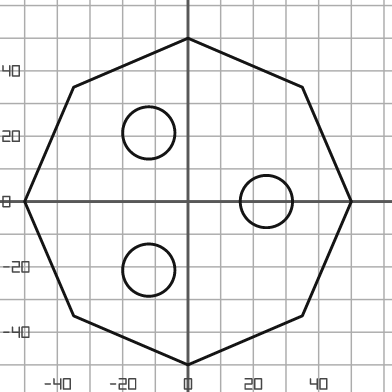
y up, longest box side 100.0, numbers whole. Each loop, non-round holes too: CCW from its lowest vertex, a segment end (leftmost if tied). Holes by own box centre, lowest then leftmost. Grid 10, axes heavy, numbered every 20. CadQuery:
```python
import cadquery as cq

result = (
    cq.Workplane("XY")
    .moveTo(0.0, -50.0)
    .lineTo(35.0, -35.0)
    .lineTo(50.0, 0.0)
    .lineTo(35.0, 35.0)
    .lineTo(0.0, 50.0)
    .lineTo(-35.0, 35.0)
    .lineTo(-50.0, 0.0)
    .lineTo(-35.0, -35.0)
    .close()
    .moveTo(-12.0, -21.0)
    .circle(8.0)
    .moveTo(24.0, 0.0)
    .circle(8.0)
    .moveTo(-12.0, 21.0)
    .circle(8.0)
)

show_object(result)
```